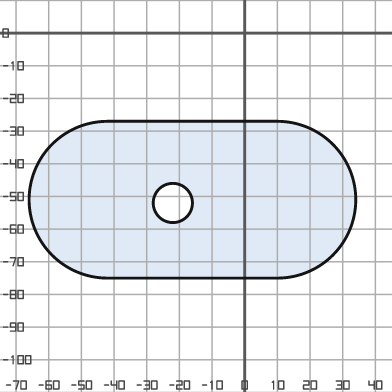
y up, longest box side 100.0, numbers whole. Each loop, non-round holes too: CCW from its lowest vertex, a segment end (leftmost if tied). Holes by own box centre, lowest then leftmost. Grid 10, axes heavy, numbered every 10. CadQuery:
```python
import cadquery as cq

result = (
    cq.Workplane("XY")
    .moveTo(-42.0, -75.0)
    .lineTo(10.0, -75.0)
    .threePointArc((34.0, -51.0), (10.0, -27.0))
    .lineTo(-42.0, -27.0)
    .threePointArc((-66.0, -51.0), (-42.0, -75.0))
    .close()
    .moveTo(-22.0, -52.0)
    .circle(6.0)
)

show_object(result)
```